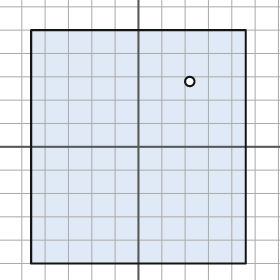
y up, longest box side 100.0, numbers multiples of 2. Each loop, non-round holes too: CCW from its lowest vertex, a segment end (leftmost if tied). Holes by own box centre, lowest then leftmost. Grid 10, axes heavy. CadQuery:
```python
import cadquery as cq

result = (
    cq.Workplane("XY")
    .moveTo(-46.0, -50.0)
    .lineTo(46.0, -50.0)
    .lineTo(46.0, 50.0)
    .lineTo(-46.0, 50.0)
    .close()
    .moveTo(22.0, 28.0)
    .circle(2.0)
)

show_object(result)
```